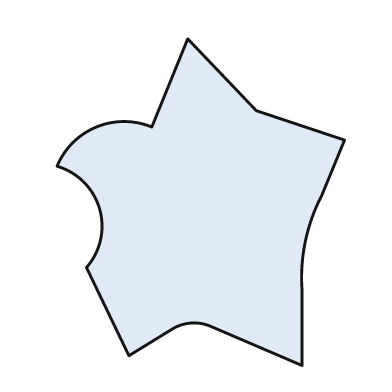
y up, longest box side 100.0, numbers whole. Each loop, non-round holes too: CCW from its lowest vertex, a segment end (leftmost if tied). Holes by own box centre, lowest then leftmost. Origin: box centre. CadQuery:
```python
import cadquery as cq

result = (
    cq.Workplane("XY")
    .moveTo(31.0, -50.0)
    .lineTo(31.0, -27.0)
    .threePointArc((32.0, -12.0), (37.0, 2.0))
    .lineTo(44.0, 19.0)
    .lineTo(17.0, 28.0)
    .lineTo(-4.0, 50.0)
    .lineTo(-15.0, 23.0)
    .threePointArc((-32.0, 23.0), (-44.0, 11.0))
    .threePointArc((-31.0, -2.0), (-35.0, -20.0))
    .lineTo(-22.0, -47.0)
    .lineTo(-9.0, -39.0)
    .threePointArc((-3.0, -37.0), (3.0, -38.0))
    .close()
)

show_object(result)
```